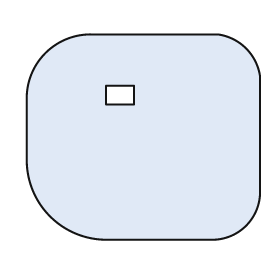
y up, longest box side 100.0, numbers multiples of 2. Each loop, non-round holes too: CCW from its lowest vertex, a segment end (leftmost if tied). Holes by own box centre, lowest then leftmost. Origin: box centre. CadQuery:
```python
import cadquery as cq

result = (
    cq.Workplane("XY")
    .moveTo(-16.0, -44.0)
    .lineTo(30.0, -44.0)
    .threePointArc((44.0, -38.0), (50.0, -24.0))
    .lineTo(50.0, 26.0)
    .threePointArc((44.0, 38.0), (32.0, 44.0))
    .lineTo(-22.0, 44.0)
    .threePointArc((-42.0, 36.0), (-50.0, 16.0))
    .lineTo(-50.0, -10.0)
    .threePointArc((-40.0, -34.0), (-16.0, -44.0))
    .close()
    .moveTo(-16.0, 14.0)
    .lineTo(-4.0, 14.0)
    .lineTo(-4.0, 22.0)
    .lineTo(-16.0, 22.0)
    .close()
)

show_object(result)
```